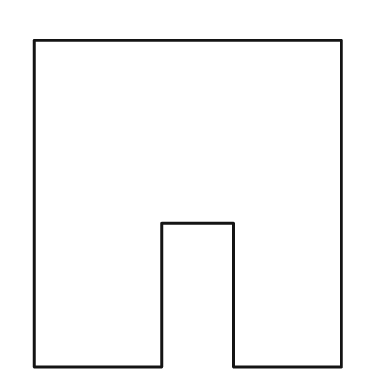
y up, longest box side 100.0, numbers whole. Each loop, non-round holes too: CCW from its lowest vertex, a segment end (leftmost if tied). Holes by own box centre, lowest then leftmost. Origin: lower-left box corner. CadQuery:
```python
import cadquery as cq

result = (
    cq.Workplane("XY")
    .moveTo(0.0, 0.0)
    .lineTo(39.0, 0.0)
    .lineTo(39.0, 44.0)
    .lineTo(61.0, 44.0)
    .lineTo(61.0, 0.0)
    .lineTo(94.0, 0.0)
    .lineTo(94.0, 100.0)
    .lineTo(0.0, 100.0)
    .close()
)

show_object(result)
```